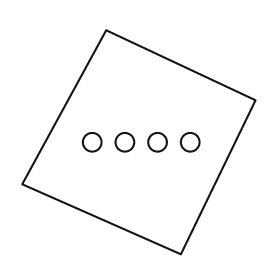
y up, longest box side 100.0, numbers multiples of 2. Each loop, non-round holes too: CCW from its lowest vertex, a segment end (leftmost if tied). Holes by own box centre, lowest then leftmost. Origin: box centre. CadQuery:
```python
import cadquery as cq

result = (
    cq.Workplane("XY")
    .moveTo(18.0, -48.0)
    .lineTo(50.0, 18.0)
    .lineTo(-14.0, 48.0)
    .lineTo(-50.0, -18.0)
    .close()
    .moveTo(-20.0, 0.0)
    .circle(4.0)
    .moveTo(-6.0, 0.0)
    .circle(4.0)
    .moveTo(8.0, 0.0)
    .circle(4.0)
    .moveTo(22.0, 0.0)
    .circle(4.0)
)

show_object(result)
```